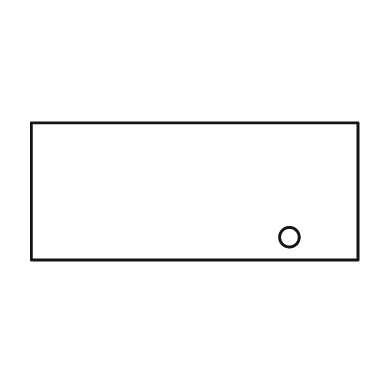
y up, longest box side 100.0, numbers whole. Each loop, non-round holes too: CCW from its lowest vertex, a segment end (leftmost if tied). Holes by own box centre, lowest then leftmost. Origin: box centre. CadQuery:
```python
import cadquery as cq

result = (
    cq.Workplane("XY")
    .moveTo(-50.0, -21.0)
    .lineTo(50.0, -21.0)
    .lineTo(50.0, 21.0)
    .lineTo(-50.0, 21.0)
    .close()
    .moveTo(29.0, -14.0)
    .circle(3.0)
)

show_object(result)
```